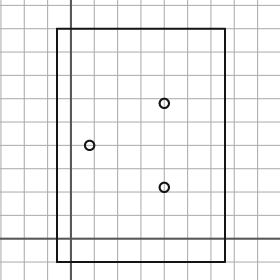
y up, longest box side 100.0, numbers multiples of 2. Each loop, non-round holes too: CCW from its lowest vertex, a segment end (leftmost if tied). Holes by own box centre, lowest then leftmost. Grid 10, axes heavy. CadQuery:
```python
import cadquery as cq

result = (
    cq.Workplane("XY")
    .moveTo(-6.0, -10.0)
    .lineTo(66.0, -10.0)
    .lineTo(66.0, 90.0)
    .lineTo(-6.0, 90.0)
    .close()
    .moveTo(40.0, 22.0)
    .circle(2.0)
    .moveTo(8.0, 40.0)
    .circle(2.0)
    .moveTo(40.0, 58.0)
    .circle(2.0)
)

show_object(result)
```